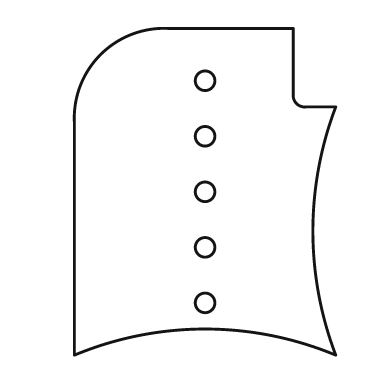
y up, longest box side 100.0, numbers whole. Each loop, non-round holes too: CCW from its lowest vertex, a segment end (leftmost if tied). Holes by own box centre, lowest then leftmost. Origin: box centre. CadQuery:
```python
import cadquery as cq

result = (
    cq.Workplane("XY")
    .moveTo(-40.0, -50.0)
    .threePointArc((0.0, -42.0), (40.0, -50.0))
    .threePointArc((33.0, -12.0), (40.0, 26.0))
    .lineTo(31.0, 26.0)
    .threePointArc((28.0, 27.0), (27.0, 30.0))
    .lineTo(27.0, 50.0)
    .lineTo(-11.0, 50.0)
    .threePointArc((-32.0, 42.0), (-40.0, 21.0))
    .close()
    .moveTo(0.0, -34.0)
    .circle(3.0)
    .moveTo(0.0, -17.0)
    .circle(3.0)
    .moveTo(0.0, 0.0)
    .circle(3.0)
    .moveTo(0.0, 17.0)
    .circle(3.0)
    .moveTo(0.0, 34.0)
    .circle(3.0)
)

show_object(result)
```